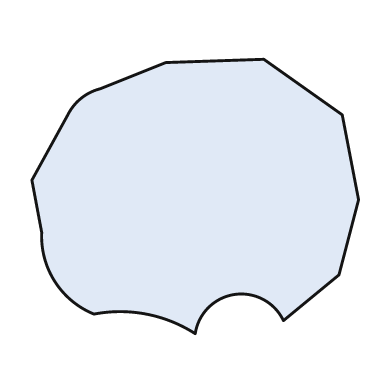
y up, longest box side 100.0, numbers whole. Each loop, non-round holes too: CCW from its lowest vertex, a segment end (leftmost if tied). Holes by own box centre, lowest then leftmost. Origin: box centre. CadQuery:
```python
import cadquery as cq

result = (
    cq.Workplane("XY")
    .moveTo(0.0, -42.0)
    .threePointArc((12.0, -30.0), (27.0, -38.0))
    .lineTo(44.0, -24.0)
    .lineTo(50.0, -1.0)
    .lineTo(45.0, 25.0)
    .lineTo(21.0, 42.0)
    .lineTo(-9.0, 41.0)
    .lineTo(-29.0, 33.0)
    .threePointArc((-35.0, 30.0), (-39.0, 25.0))
    .lineTo(-50.0, 5.0)
    .lineTo(-47.0, -11.0)
    .threePointArc((-43.0, -26.0), (-31.0, -36.0))
    .threePointArc((-15.0, -36.0), (0.0, -42.0))
    .close()
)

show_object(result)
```